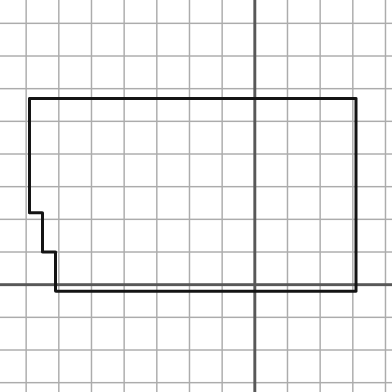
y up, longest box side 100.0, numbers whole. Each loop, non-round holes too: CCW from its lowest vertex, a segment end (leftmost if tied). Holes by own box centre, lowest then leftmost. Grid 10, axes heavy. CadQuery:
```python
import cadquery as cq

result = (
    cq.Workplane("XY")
    .moveTo(-61.0, -2.0)
    .lineTo(31.0, -2.0)
    .lineTo(31.0, 57.0)
    .lineTo(-69.0, 57.0)
    .lineTo(-69.0, 22.0)
    .lineTo(-65.0, 22.0)
    .lineTo(-65.0, 10.0)
    .lineTo(-61.0, 10.0)
    .close()
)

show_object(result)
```